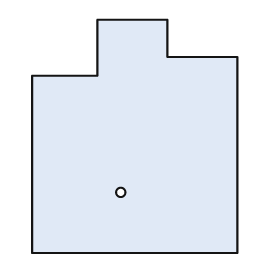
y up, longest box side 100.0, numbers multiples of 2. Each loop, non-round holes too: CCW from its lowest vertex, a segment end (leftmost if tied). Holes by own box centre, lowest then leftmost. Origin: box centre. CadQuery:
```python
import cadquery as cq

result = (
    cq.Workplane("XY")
    .moveTo(-44.0, -50.0)
    .lineTo(44.0, -50.0)
    .lineTo(44.0, 34.0)
    .lineTo(14.0, 34.0)
    .lineTo(14.0, 50.0)
    .lineTo(-16.0, 50.0)
    .lineTo(-16.0, 26.0)
    .lineTo(-44.0, 26.0)
    .close()
    .moveTo(-6.0, -24.0)
    .circle(2.0)
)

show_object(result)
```